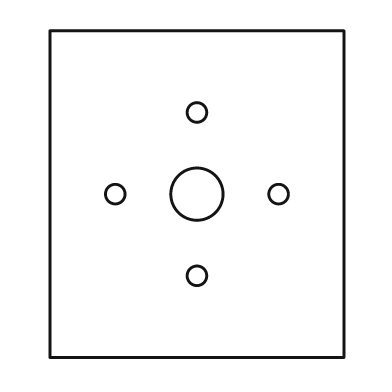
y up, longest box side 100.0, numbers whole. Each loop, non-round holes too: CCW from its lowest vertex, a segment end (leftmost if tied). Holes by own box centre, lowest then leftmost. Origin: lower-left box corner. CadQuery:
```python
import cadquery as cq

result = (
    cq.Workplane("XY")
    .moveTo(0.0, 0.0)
    .lineTo(90.0, 0.0)
    .lineTo(90.0, 100.0)
    .lineTo(0.0, 100.0)
    .close()
    .moveTo(45.0, 25.0)
    .circle(3.0)
    .moveTo(20.0, 50.0)
    .circle(3.0)
    .moveTo(45.0, 50.0)
    .circle(8.0)
    .moveTo(70.0, 50.0)
    .circle(3.0)
    .moveTo(45.0, 75.0)
    .circle(3.0)
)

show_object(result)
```